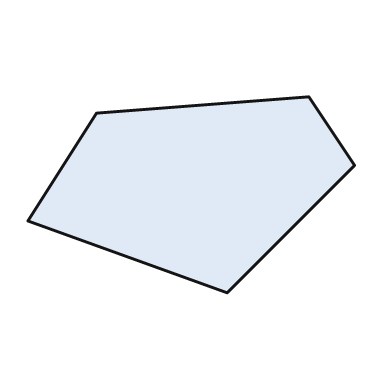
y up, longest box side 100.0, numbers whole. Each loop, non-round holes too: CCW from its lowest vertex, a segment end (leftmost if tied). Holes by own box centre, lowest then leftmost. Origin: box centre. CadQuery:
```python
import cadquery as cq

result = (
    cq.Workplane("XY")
    .moveTo(11.0, -30.0)
    .lineTo(50.0, 9.0)
    .lineTo(36.0, 30.0)
    .lineTo(-29.0, 25.0)
    .lineTo(-50.0, -8.0)
    .close()
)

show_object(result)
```